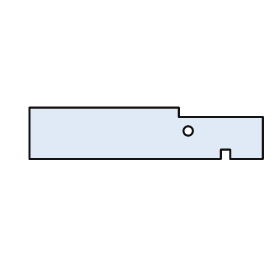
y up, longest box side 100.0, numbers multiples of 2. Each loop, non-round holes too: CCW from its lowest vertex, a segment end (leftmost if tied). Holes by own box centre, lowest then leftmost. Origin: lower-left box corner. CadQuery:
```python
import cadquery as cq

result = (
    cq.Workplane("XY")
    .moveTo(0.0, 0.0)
    .lineTo(82.0, 0.0)
    .lineTo(82.0, 4.0)
    .lineTo(86.0, 4.0)
    .lineTo(86.0, 0.0)
    .lineTo(100.0, 0.0)
    .lineTo(100.0, 18.0)
    .lineTo(64.0, 18.0)
    .lineTo(64.0, 22.0)
    .lineTo(0.0, 22.0)
    .close()
    .moveTo(68.0, 12.0)
    .circle(2.0)
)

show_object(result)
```